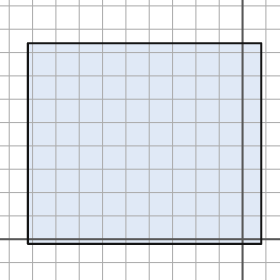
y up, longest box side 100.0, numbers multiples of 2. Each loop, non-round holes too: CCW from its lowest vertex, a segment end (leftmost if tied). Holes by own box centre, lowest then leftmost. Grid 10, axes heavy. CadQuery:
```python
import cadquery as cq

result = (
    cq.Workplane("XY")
    .moveTo(-92.0, -2.0)
    .lineTo(8.0, -2.0)
    .lineTo(8.0, 84.0)
    .lineTo(-92.0, 84.0)
    .close()
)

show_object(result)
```